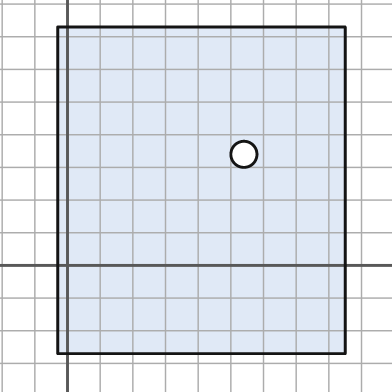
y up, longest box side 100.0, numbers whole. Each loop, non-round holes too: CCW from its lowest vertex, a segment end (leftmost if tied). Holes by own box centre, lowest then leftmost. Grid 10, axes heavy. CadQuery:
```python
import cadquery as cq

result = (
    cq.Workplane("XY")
    .moveTo(-3.0, -27.0)
    .lineTo(85.0, -27.0)
    .lineTo(85.0, 73.0)
    .lineTo(-3.0, 73.0)
    .close()
    .moveTo(54.0, 34.0)
    .circle(4.0)
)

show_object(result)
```